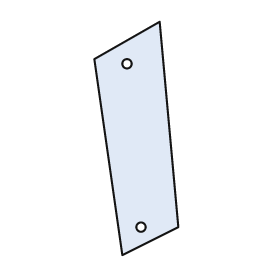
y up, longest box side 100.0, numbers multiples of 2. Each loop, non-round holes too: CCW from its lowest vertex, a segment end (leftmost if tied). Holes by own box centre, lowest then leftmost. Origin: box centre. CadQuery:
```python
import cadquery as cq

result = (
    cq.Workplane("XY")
    .moveTo(-6.0, -50.0)
    .lineTo(18.0, -38.0)
    .lineTo(10.0, 50.0)
    .lineTo(-18.0, 34.0)
    .close()
    .moveTo(2.0, -38.0)
    .circle(2.0)
    .moveTo(-4.0, 32.0)
    .circle(2.0)
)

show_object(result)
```